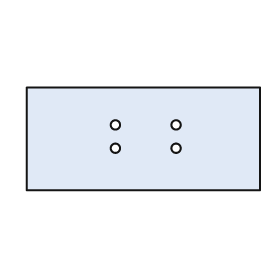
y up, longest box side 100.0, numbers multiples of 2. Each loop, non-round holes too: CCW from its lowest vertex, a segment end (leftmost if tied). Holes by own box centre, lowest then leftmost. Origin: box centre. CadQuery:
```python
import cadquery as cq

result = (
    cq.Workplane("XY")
    .moveTo(-50.0, -22.0)
    .lineTo(50.0, -22.0)
    .lineTo(50.0, 22.0)
    .lineTo(-50.0, 22.0)
    .close()
    .moveTo(-12.0, -4.0)
    .circle(2.0)
    .moveTo(14.0, -4.0)
    .circle(2.0)
    .moveTo(-12.0, 6.0)
    .circle(2.0)
    .moveTo(14.0, 6.0)
    .circle(2.0)
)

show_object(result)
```